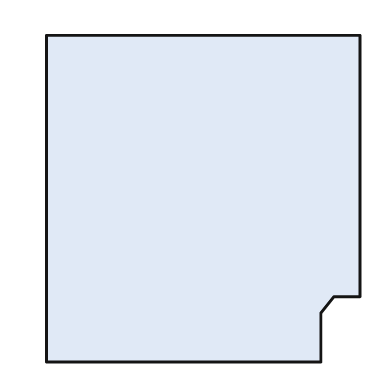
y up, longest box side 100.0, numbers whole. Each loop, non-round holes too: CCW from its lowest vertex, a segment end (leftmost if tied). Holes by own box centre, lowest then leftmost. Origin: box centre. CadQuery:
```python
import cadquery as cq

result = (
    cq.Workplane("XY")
    .moveTo(-48.0, -50.0)
    .lineTo(36.0, -50.0)
    .lineTo(36.0, -35.0)
    .lineTo(40.0, -30.0)
    .lineTo(48.0, -30.0)
    .lineTo(48.0, 50.0)
    .lineTo(-48.0, 50.0)
    .close()
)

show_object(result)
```